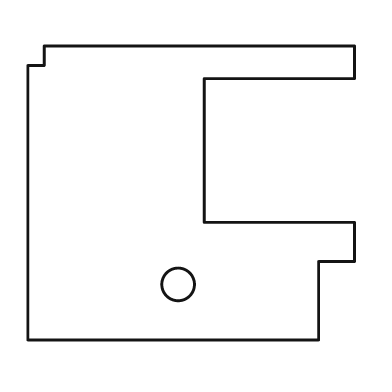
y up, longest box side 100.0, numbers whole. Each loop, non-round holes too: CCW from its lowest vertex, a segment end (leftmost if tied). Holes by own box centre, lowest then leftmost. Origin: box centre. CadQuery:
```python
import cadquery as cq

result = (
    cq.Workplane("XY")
    .moveTo(-50.0, -45.0)
    .lineTo(39.0, -45.0)
    .lineTo(39.0, -21.0)
    .lineTo(50.0, -21.0)
    .lineTo(50.0, -9.0)
    .lineTo(4.0, -9.0)
    .lineTo(4.0, 35.0)
    .lineTo(50.0, 35.0)
    .lineTo(50.0, 45.0)
    .lineTo(-45.0, 45.0)
    .lineTo(-45.0, 39.0)
    .lineTo(-50.0, 39.0)
    .close()
    .moveTo(-4.0, -28.0)
    .circle(5.0)
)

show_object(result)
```